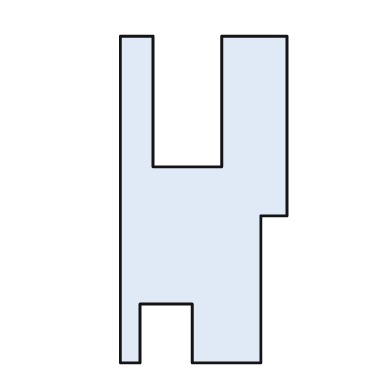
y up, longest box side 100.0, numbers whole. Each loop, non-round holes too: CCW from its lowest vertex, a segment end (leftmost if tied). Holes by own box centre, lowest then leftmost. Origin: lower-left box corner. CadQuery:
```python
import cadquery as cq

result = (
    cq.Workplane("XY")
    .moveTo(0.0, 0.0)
    .lineTo(6.0, 0.0)
    .lineTo(6.0, 18.0)
    .lineTo(22.0, 18.0)
    .lineTo(22.0, 0.0)
    .lineTo(43.0, 0.0)
    .lineTo(43.0, 45.0)
    .lineTo(51.0, 45.0)
    .lineTo(51.0, 100.0)
    .lineTo(31.0, 100.0)
    .lineTo(31.0, 60.0)
    .lineTo(10.0, 60.0)
    .lineTo(10.0, 100.0)
    .lineTo(0.0, 100.0)
    .close()
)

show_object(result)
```